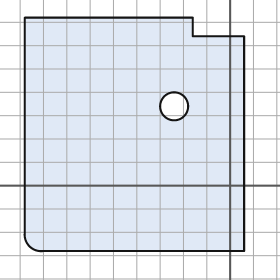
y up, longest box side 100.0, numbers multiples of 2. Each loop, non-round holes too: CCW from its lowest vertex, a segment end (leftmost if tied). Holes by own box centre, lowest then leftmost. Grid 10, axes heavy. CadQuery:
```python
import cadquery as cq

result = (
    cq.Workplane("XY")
    .moveTo(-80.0, -28.0)
    .lineTo(6.0, -28.0)
    .lineTo(6.0, 64.0)
    .lineTo(-16.0, 64.0)
    .lineTo(-16.0, 72.0)
    .lineTo(-88.0, 72.0)
    .lineTo(-88.0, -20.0)
    .threePointArc((-86.0, -26.0), (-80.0, -28.0))
    .close()
    .moveTo(-24.0, 34.0)
    .circle(6.0)
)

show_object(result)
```